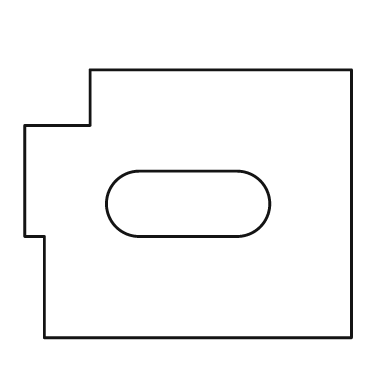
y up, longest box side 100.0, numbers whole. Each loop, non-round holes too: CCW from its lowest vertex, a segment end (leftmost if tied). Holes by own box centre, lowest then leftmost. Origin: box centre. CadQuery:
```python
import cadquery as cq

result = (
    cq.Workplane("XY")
    .moveTo(-44.0, -41.0)
    .lineTo(50.0, -41.0)
    .lineTo(50.0, 41.0)
    .lineTo(-30.0, 41.0)
    .lineTo(-30.0, 24.0)
    .lineTo(-50.0, 24.0)
    .lineTo(-50.0, -10.0)
    .lineTo(-44.0, -10.0)
    .close()
    .moveTo(-15.0, -10.0)
    .lineTo(15.0, -10.0)
    .threePointArc((25.0, 0.0), (15.0, 10.0))
    .lineTo(-15.0, 10.0)
    .threePointArc((-25.0, 0.0), (-15.0, -10.0))
    .close()
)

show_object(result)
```